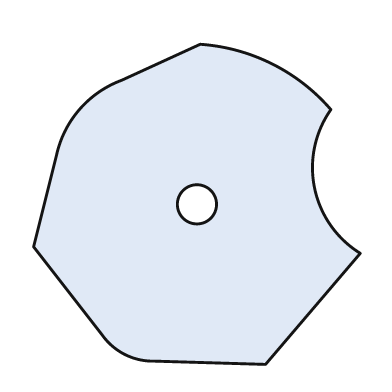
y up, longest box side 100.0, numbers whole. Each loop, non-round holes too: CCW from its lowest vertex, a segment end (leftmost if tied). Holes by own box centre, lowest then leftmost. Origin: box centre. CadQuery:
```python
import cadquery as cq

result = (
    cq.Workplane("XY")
    .moveTo(21.0, -49.0)
    .lineTo(50.0, -15.0)
    .threePointArc((36.0, 5.0), (41.0, 29.0))
    .threePointArc((23.0, 43.0), (1.0, 49.0))
    .lineTo(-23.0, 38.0)
    .threePointArc((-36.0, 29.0), (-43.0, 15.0))
    .lineTo(-50.0, -13.0)
    .lineTo(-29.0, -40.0)
    .threePointArc((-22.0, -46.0), (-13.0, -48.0))
    .close()
    .moveTo(0.0, 0.0)
    .circle(6.0)
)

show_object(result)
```